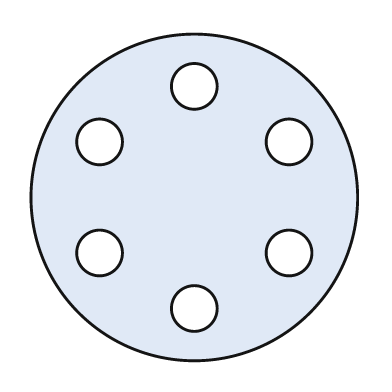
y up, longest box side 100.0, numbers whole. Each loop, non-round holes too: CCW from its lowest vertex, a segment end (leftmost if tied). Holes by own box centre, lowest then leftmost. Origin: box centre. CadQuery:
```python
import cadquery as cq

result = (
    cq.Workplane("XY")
    .moveTo(0.0, 0.0)
    .circle(50.0)
    .moveTo(0.0, -34.0)
    .circle(7.0)
    .moveTo(-29.0, -17.0)
    .circle(7.0)
    .moveTo(29.0, -17.0)
    .circle(7.0)
    .moveTo(-29.0, 17.0)
    .circle(7.0)
    .moveTo(29.0, 17.0)
    .circle(7.0)
    .moveTo(0.0, 34.0)
    .circle(7.0)
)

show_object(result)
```